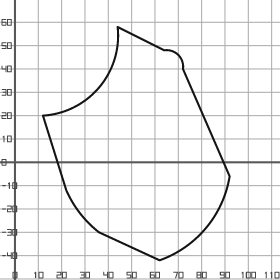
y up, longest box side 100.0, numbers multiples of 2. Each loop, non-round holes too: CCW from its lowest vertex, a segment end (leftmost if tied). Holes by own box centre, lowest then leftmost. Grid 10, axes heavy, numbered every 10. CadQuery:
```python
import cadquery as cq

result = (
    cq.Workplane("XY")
    .moveTo(62.0, -42.0)
    .threePointArc((82.0, -28.0), (92.0, -6.0))
    .lineTo(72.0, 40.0)
    .threePointArc((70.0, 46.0), (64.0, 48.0))
    .lineTo(44.0, 58.0)
    .threePointArc((36.0, 32.0), (12.0, 20.0))
    .lineTo(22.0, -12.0)
    .threePointArc((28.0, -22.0), (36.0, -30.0))
    .close()
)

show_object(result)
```